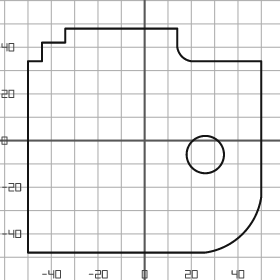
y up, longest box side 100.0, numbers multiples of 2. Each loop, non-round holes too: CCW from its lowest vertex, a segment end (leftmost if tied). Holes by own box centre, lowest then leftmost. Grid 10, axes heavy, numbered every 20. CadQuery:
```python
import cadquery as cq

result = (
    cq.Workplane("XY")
    .moveTo(-50.0, -48.0)
    .lineTo(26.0, -48.0)
    .threePointArc((42.0, -40.0), (50.0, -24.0))
    .lineTo(50.0, 34.0)
    .lineTo(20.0, 34.0)
    .threePointArc((16.0, 36.0), (14.0, 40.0))
    .lineTo(14.0, 48.0)
    .lineTo(-34.0, 48.0)
    .lineTo(-34.0, 42.0)
    .lineTo(-44.0, 42.0)
    .lineTo(-44.0, 34.0)
    .lineTo(-50.0, 34.0)
    .close()
    .moveTo(26.0, -6.0)
    .circle(8.0)
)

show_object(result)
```